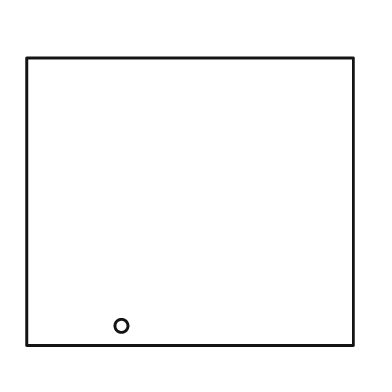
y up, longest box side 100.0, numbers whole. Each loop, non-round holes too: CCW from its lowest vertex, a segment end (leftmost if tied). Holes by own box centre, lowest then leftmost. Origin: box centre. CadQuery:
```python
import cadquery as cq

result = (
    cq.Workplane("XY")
    .moveTo(-50.0, -44.0)
    .lineTo(50.0, -44.0)
    .lineTo(50.0, 44.0)
    .lineTo(-50.0, 44.0)
    .close()
    .moveTo(-21.0, -38.0)
    .circle(2.0)
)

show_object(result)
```